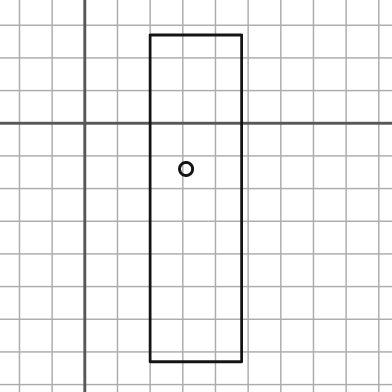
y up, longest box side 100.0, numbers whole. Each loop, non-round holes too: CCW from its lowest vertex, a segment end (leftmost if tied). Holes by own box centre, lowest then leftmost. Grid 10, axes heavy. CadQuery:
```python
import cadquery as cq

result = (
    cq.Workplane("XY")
    .moveTo(20.0, -73.0)
    .lineTo(48.0, -73.0)
    .lineTo(48.0, 27.0)
    .lineTo(20.0, 27.0)
    .close()
    .moveTo(31.0, -14.0)
    .circle(2.0)
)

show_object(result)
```